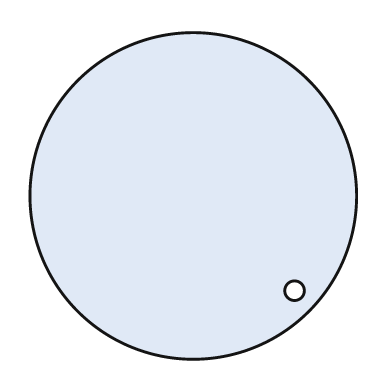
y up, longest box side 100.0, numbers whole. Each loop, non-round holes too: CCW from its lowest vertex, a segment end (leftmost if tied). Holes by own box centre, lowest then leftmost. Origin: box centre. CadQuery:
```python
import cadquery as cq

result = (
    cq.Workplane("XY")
    .moveTo(0.0, 0.0)
    .circle(50.0)
    .moveTo(31.0, -29.0)
    .circle(3.0)
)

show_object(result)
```